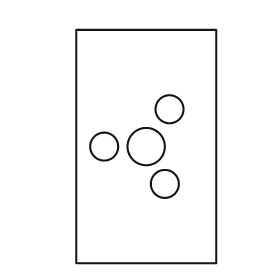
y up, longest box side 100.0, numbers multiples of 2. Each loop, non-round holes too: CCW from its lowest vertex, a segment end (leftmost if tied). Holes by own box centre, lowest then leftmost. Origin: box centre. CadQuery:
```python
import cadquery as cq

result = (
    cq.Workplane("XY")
    .moveTo(-30.0, -50.0)
    .lineTo(30.0, -50.0)
    .lineTo(30.0, 50.0)
    .lineTo(-30.0, 50.0)
    .close()
    .moveTo(8.0, -16.0)
    .circle(6.0)
    .moveTo(-18.0, 0.0)
    .circle(6.0)
    .moveTo(0.0, 0.0)
    .circle(8.0)
    .moveTo(10.0, 16.0)
    .circle(6.0)
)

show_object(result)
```